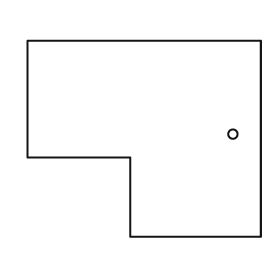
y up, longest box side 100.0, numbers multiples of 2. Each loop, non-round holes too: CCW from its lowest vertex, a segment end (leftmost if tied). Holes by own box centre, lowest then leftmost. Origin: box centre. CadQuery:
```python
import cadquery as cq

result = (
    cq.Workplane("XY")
    .moveTo(-6.0, -42.0)
    .lineTo(50.0, -42.0)
    .lineTo(50.0, 42.0)
    .lineTo(-50.0, 42.0)
    .lineTo(-50.0, -8.0)
    .lineTo(-6.0, -8.0)
    .close()
    .moveTo(38.0, 2.0)
    .circle(2.0)
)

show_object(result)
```